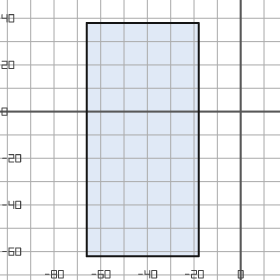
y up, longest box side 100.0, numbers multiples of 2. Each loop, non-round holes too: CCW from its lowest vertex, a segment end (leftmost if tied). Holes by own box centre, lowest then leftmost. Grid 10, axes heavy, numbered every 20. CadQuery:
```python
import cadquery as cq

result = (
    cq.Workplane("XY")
    .moveTo(-66.0, -62.0)
    .lineTo(-18.0, -62.0)
    .lineTo(-18.0, 38.0)
    .lineTo(-66.0, 38.0)
    .close()
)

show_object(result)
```